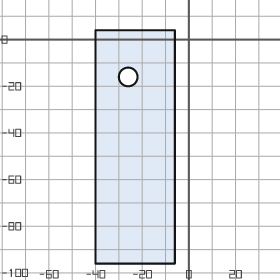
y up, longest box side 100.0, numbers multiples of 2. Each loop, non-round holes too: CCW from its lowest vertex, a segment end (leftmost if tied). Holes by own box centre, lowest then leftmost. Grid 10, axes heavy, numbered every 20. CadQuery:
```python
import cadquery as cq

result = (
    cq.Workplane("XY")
    .moveTo(-40.0, -96.0)
    .lineTo(-6.0, -96.0)
    .lineTo(-6.0, 4.0)
    .lineTo(-40.0, 4.0)
    .close()
    .moveTo(-26.0, -16.0)
    .circle(4.0)
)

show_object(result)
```